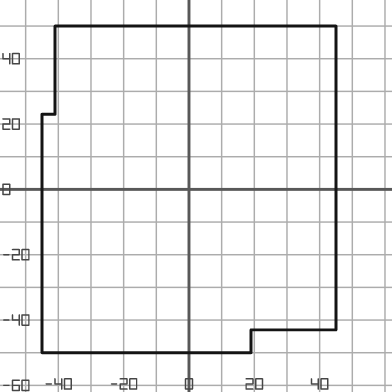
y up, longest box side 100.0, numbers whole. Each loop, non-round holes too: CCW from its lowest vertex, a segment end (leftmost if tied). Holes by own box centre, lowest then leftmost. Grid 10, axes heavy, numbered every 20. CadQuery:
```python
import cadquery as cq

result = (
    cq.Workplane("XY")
    .moveTo(-45.0, -50.0)
    .lineTo(19.0, -50.0)
    .lineTo(19.0, -43.0)
    .lineTo(45.0, -43.0)
    .lineTo(45.0, 50.0)
    .lineTo(-41.0, 50.0)
    .lineTo(-41.0, 23.0)
    .lineTo(-45.0, 23.0)
    .close()
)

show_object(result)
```